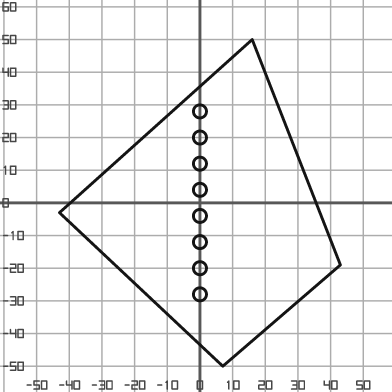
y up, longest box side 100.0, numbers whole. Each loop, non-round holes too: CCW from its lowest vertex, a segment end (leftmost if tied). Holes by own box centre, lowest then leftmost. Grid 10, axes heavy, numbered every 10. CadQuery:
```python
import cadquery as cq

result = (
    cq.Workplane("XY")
    .moveTo(7.0, -50.0)
    .lineTo(43.0, -19.0)
    .lineTo(16.0, 50.0)
    .lineTo(-43.0, -3.0)
    .close()
    .moveTo(0.0, -28.0)
    .circle(2.0)
    .moveTo(0.0, -20.0)
    .circle(2.0)
    .moveTo(0.0, -12.0)
    .circle(2.0)
    .moveTo(0.0, -4.0)
    .circle(2.0)
    .moveTo(0.0, 4.0)
    .circle(2.0)
    .moveTo(0.0, 12.0)
    .circle(2.0)
    .moveTo(0.0, 20.0)
    .circle(2.0)
    .moveTo(0.0, 28.0)
    .circle(2.0)
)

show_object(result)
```